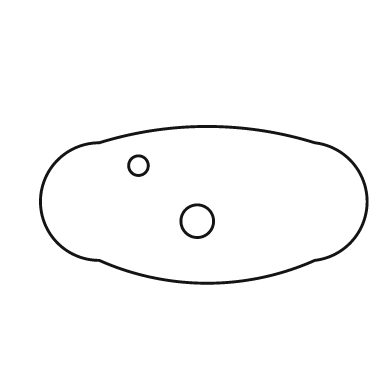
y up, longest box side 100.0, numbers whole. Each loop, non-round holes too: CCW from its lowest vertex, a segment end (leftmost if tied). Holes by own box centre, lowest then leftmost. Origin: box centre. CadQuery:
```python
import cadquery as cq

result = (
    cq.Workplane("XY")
    .moveTo(-32.0, -17.0)
    .threePointArc((1.0, -24.0), (34.0, -17.0))
    .threePointArc((50.0, 1.0), (34.0, 19.0))
    .threePointArc((1.0, 24.0), (-32.0, 19.0))
    .threePointArc((-50.0, 1.0), (-32.0, -17.0))
    .close()
    .moveTo(-2.0, -5.0)
    .circle(5.0)
    .moveTo(-20.0, 12.0)
    .circle(3.0)
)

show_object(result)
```